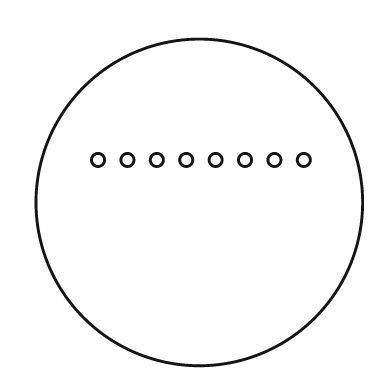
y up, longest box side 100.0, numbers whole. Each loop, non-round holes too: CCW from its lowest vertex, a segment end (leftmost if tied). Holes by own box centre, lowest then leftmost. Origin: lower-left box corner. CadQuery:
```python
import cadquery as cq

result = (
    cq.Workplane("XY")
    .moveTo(50.0, 50.0)
    .circle(50.0)
    .moveTo(19.0, 63.0)
    .circle(2.0)
    .moveTo(28.0, 63.0)
    .circle(2.0)
    .moveTo(37.0, 63.0)
    .circle(2.0)
    .moveTo(46.0, 63.0)
    .circle(2.0)
    .moveTo(55.0, 63.0)
    .circle(2.0)
    .moveTo(64.0, 63.0)
    .circle(2.0)
    .moveTo(73.0, 63.0)
    .circle(2.0)
    .moveTo(82.0, 63.0)
    .circle(2.0)
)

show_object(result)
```